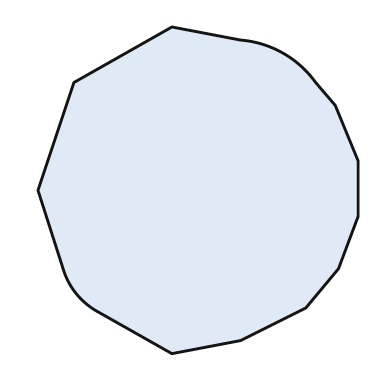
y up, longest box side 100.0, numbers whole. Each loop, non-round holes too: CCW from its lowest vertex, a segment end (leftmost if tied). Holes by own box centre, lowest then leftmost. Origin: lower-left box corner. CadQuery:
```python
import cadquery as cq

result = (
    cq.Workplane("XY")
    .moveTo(41.0, 0.0)
    .lineTo(62.0, 4.0)
    .lineTo(82.0, 14.0)
    .lineTo(92.0, 26.0)
    .lineTo(98.0, 42.0)
    .lineTo(98.0, 59.0)
    .lineTo(91.0, 76.0)
    .lineTo(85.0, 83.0)
    .threePointArc((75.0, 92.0), (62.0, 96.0))
    .lineTo(41.0, 100.0)
    .lineTo(11.0, 83.0)
    .lineTo(0.0, 50.0)
    .lineTo(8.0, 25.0)
    .threePointArc((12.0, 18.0), (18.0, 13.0))
    .close()
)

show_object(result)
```